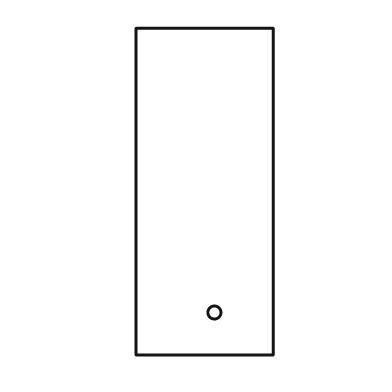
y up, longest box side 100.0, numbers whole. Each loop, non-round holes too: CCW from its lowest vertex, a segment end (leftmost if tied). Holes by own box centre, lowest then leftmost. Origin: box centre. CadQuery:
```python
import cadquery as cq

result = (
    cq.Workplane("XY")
    .moveTo(-21.0, -50.0)
    .lineTo(21.0, -50.0)
    .lineTo(21.0, 50.0)
    .lineTo(-21.0, 50.0)
    .close()
    .moveTo(3.0, -37.0)
    .circle(2.0)
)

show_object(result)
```